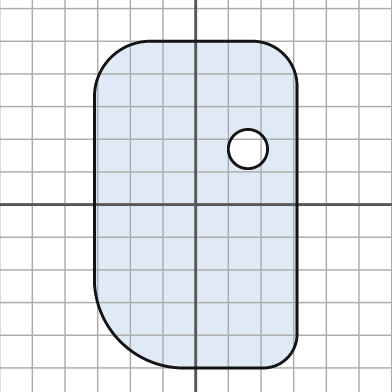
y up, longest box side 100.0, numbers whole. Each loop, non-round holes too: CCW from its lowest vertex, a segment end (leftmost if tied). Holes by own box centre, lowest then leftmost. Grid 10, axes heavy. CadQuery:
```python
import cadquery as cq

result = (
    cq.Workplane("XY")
    .moveTo(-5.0, -50.0)
    .lineTo(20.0, -50.0)
    .threePointArc((28.0, -47.0), (31.0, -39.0))
    .lineTo(31.0, 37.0)
    .threePointArc((27.0, 46.0), (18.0, 50.0))
    .lineTo(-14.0, 50.0)
    .threePointArc((-26.0, 45.0), (-31.0, 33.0))
    .lineTo(-31.0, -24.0)
    .threePointArc((-23.0, -42.0), (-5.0, -50.0))
    .close()
    .moveTo(16.0, 17.0)
    .circle(6.0)
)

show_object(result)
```